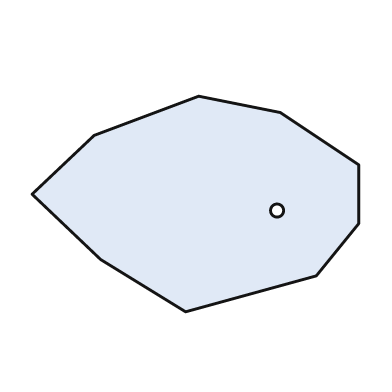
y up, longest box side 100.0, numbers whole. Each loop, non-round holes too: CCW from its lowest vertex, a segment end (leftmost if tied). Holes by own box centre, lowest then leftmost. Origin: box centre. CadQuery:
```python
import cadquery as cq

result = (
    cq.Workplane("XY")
    .moveTo(-3.0, -33.0)
    .lineTo(37.0, -22.0)
    .lineTo(50.0, -6.0)
    .lineTo(50.0, 12.0)
    .lineTo(26.0, 28.0)
    .lineTo(1.0, 33.0)
    .lineTo(-31.0, 21.0)
    .lineTo(-50.0, 3.0)
    .lineTo(-29.0, -17.0)
    .close()
    .moveTo(25.0, -2.0)
    .circle(2.0)
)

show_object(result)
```